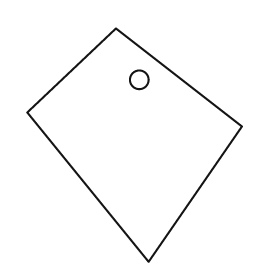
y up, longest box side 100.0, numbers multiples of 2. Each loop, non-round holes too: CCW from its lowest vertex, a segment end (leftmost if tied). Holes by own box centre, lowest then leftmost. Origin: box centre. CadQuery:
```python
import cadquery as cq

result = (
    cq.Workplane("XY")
    .moveTo(6.0, -50.0)
    .lineTo(46.0, 8.0)
    .lineTo(-8.0, 50.0)
    .lineTo(-46.0, 14.0)
    .close()
    .moveTo(2.0, 28.0)
    .circle(4.0)
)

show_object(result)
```